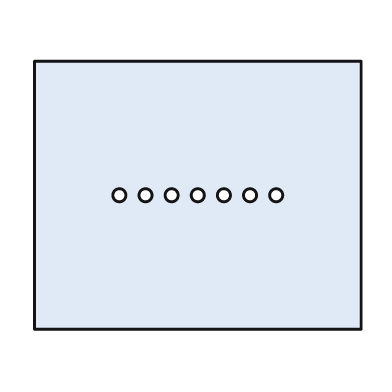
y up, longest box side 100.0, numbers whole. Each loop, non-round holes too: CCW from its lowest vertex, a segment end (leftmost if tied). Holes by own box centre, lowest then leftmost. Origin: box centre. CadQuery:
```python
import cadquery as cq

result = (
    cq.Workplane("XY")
    .moveTo(-50.0, -41.0)
    .lineTo(50.0, -41.0)
    .lineTo(50.0, 41.0)
    .lineTo(-50.0, 41.0)
    .close()
    .moveTo(-24.0, 0.0)
    .circle(2.0)
    .moveTo(-16.0, 0.0)
    .circle(2.0)
    .moveTo(-8.0, 0.0)
    .circle(2.0)
    .moveTo(0.0, 0.0)
    .circle(2.0)
    .moveTo(8.0, 0.0)
    .circle(2.0)
    .moveTo(16.0, 0.0)
    .circle(2.0)
    .moveTo(24.0, 0.0)
    .circle(2.0)
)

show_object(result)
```